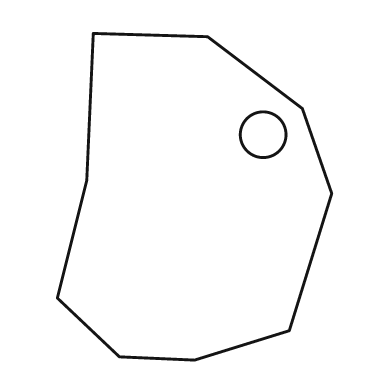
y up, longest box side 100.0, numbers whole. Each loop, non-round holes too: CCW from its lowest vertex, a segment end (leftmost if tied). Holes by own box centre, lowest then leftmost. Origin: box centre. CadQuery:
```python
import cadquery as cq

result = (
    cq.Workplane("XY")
    .moveTo(0.0, -50.0)
    .lineTo(29.0, -41.0)
    .lineTo(42.0, 1.0)
    .lineTo(33.0, 27.0)
    .lineTo(4.0, 49.0)
    .lineTo(-31.0, 50.0)
    .lineTo(-33.0, 5.0)
    .lineTo(-42.0, -31.0)
    .lineTo(-23.0, -49.0)
    .close()
    .moveTo(21.0, 19.0)
    .circle(7.0)
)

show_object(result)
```